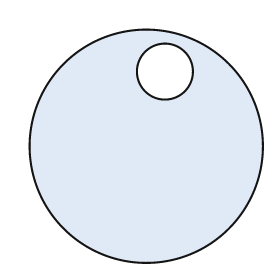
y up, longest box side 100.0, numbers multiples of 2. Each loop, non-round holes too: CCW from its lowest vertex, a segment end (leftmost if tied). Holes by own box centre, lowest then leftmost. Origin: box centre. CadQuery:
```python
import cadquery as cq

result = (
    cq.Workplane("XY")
    .moveTo(0.0, 0.0)
    .circle(50.0)
    .moveTo(8.0, 32.0)
    .circle(12.0)
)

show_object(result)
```